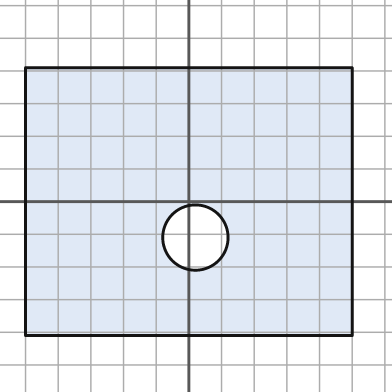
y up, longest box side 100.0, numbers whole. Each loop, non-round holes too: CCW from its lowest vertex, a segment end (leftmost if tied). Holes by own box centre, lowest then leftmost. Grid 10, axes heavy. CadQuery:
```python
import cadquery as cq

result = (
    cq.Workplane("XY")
    .moveTo(-50.0, -41.0)
    .lineTo(50.0, -41.0)
    .lineTo(50.0, 41.0)
    .lineTo(-50.0, 41.0)
    .close()
    .moveTo(2.0, -11.0)
    .circle(10.0)
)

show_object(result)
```